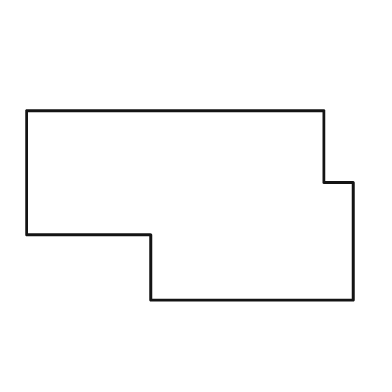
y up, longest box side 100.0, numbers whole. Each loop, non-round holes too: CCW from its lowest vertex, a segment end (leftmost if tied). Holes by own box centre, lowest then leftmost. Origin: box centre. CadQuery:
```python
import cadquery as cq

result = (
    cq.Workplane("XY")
    .moveTo(-12.0, -29.0)
    .lineTo(50.0, -29.0)
    .lineTo(50.0, 7.0)
    .lineTo(41.0, 7.0)
    .lineTo(41.0, 29.0)
    .lineTo(-50.0, 29.0)
    .lineTo(-50.0, -9.0)
    .lineTo(-12.0, -9.0)
    .close()
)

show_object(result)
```